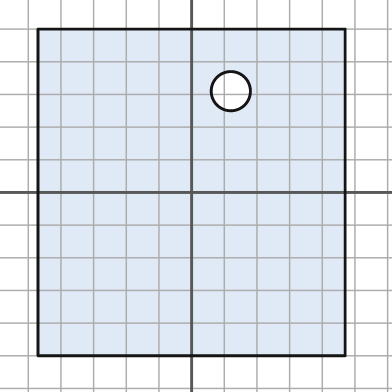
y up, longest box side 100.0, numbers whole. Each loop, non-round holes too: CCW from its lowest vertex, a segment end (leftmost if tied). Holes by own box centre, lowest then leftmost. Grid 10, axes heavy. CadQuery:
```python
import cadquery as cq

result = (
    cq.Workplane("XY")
    .moveTo(-47.0, -50.0)
    .lineTo(47.0, -50.0)
    .lineTo(47.0, 50.0)
    .lineTo(-47.0, 50.0)
    .close()
    .moveTo(12.0, 31.0)
    .circle(6.0)
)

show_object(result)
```